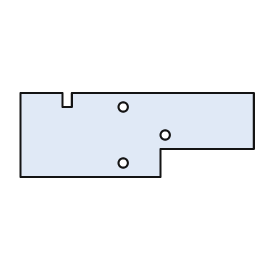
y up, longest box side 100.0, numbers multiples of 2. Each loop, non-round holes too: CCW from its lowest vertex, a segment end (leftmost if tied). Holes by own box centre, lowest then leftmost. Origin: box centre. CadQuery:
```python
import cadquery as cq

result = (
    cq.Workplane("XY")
    .moveTo(-50.0, -18.0)
    .lineTo(10.0, -18.0)
    .lineTo(10.0, -6.0)
    .lineTo(50.0, -6.0)
    .lineTo(50.0, 18.0)
    .lineTo(-28.0, 18.0)
    .lineTo(-28.0, 12.0)
    .lineTo(-32.0, 12.0)
    .lineTo(-32.0, 18.0)
    .lineTo(-50.0, 18.0)
    .close()
    .moveTo(-6.0, -12.0)
    .circle(2.0)
    .moveTo(12.0, 0.0)
    .circle(2.0)
    .moveTo(-6.0, 12.0)
    .circle(2.0)
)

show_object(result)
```